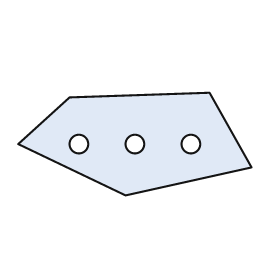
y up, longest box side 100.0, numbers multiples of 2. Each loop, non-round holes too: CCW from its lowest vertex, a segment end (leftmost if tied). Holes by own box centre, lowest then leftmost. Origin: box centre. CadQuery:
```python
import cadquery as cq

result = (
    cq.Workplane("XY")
    .moveTo(-4.0, -22.0)
    .lineTo(50.0, -10.0)
    .lineTo(32.0, 22.0)
    .lineTo(-28.0, 20.0)
    .lineTo(-50.0, 0.0)
    .close()
    .moveTo(-24.0, 0.0)
    .circle(4.0)
    .moveTo(0.0, 0.0)
    .circle(4.0)
    .moveTo(24.0, 0.0)
    .circle(4.0)
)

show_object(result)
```